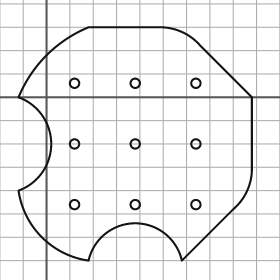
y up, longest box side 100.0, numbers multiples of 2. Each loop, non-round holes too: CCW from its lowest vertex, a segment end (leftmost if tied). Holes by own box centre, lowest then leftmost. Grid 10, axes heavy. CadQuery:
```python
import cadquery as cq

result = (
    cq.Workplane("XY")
    .moveTo(18.0, -70.0)
    .threePointArc((38.0, -54.0), (58.0, -70.0))
    .lineTo(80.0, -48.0)
    .threePointArc((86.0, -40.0), (88.0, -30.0))
    .lineTo(88.0, 0.0)
    .lineTo(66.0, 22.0)
    .threePointArc((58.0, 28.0), (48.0, 30.0))
    .lineTo(18.0, 30.0)
    .threePointArc((0.0, 18.0), (-12.0, 0.0))
    .threePointArc((2.0, -20.0), (-12.0, -40.0))
    .threePointArc((-2.0, -60.0), (18.0, -70.0))
    .close()
    .moveTo(12.0, -46.0)
    .circle(2.0)
    .moveTo(38.0, -46.0)
    .circle(2.0)
    .moveTo(64.0, -46.0)
    .circle(2.0)
    .moveTo(12.0, -20.0)
    .circle(2.0)
    .moveTo(38.0, -20.0)
    .circle(2.0)
    .moveTo(64.0, -20.0)
    .circle(2.0)
    .moveTo(12.0, 6.0)
    .circle(2.0)
    .moveTo(38.0, 6.0)
    .circle(2.0)
    .moveTo(64.0, 6.0)
    .circle(2.0)
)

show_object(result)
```